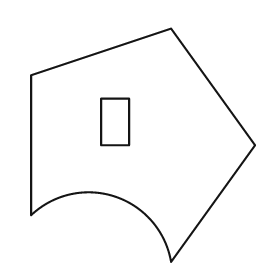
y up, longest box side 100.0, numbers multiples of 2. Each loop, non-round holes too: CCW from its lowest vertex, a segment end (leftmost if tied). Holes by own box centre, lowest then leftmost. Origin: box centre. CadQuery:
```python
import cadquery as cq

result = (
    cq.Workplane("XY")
    .moveTo(12.0, -50.0)
    .lineTo(48.0, 0.0)
    .lineTo(12.0, 50.0)
    .lineTo(-48.0, 30.0)
    .lineTo(-48.0, -30.0)
    .threePointArc((-12.0, -22.0), (12.0, -50.0))
    .close()
    .moveTo(-18.0, 0.0)
    .lineTo(-6.0, 0.0)
    .lineTo(-6.0, 20.0)
    .lineTo(-18.0, 20.0)
    .close()
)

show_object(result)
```